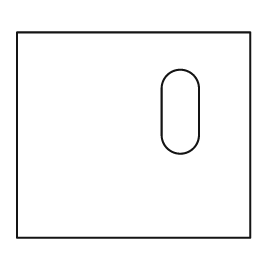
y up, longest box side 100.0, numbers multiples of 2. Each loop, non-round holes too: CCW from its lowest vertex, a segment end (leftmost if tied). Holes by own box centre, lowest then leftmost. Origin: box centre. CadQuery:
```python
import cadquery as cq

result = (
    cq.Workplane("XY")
    .moveTo(-50.0, -44.0)
    .lineTo(50.0, -44.0)
    .lineTo(50.0, 44.0)
    .lineTo(-50.0, 44.0)
    .close()
    .moveTo(12.0, 0.0)
    .threePointArc((20.0, -8.0), (28.0, 0.0))
    .lineTo(28.0, 20.0)
    .threePointArc((20.0, 28.0), (12.0, 20.0))
    .close()
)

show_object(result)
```